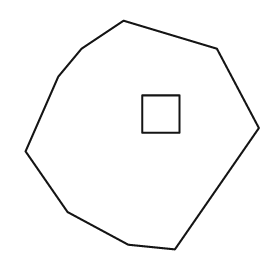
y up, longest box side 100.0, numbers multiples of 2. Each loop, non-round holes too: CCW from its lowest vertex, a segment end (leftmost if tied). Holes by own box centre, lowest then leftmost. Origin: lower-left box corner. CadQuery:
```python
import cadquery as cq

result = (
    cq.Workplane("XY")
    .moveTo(64.0, 0.0)
    .lineTo(100.0, 52.0)
    .lineTo(82.0, 86.0)
    .lineTo(42.0, 98.0)
    .lineTo(24.0, 86.0)
    .lineTo(14.0, 74.0)
    .lineTo(0.0, 42.0)
    .lineTo(18.0, 16.0)
    .lineTo(44.0, 2.0)
    .close()
    .moveTo(50.0, 50.0)
    .lineTo(66.0, 50.0)
    .lineTo(66.0, 66.0)
    .lineTo(50.0, 66.0)
    .close()
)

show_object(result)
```